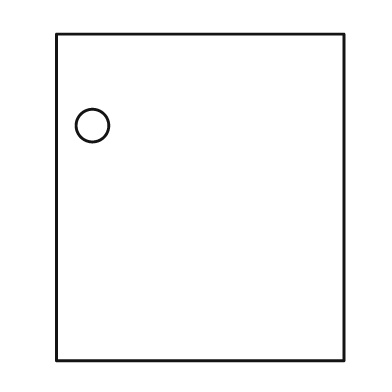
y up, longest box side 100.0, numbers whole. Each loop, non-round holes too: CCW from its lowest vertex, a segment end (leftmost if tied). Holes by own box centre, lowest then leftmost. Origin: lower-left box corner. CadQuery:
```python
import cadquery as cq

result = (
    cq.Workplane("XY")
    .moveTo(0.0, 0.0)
    .lineTo(88.0, 0.0)
    .lineTo(88.0, 100.0)
    .lineTo(0.0, 100.0)
    .close()
    .moveTo(11.0, 72.0)
    .circle(5.0)
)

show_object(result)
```